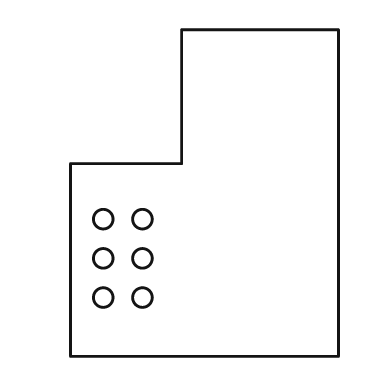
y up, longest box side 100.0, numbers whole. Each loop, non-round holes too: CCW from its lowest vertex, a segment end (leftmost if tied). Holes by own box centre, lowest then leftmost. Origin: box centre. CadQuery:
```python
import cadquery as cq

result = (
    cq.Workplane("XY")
    .moveTo(-41.0, -50.0)
    .lineTo(41.0, -50.0)
    .lineTo(41.0, 50.0)
    .lineTo(-7.0, 50.0)
    .lineTo(-7.0, 9.0)
    .lineTo(-41.0, 9.0)
    .close()
    .moveTo(-31.0, -32.0)
    .circle(3.0)
    .moveTo(-19.0, -32.0)
    .circle(3.0)
    .moveTo(-31.0, -20.0)
    .circle(3.0)
    .moveTo(-19.0, -20.0)
    .circle(3.0)
    .moveTo(-31.0, -8.0)
    .circle(3.0)
    .moveTo(-19.0, -8.0)
    .circle(3.0)
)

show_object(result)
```